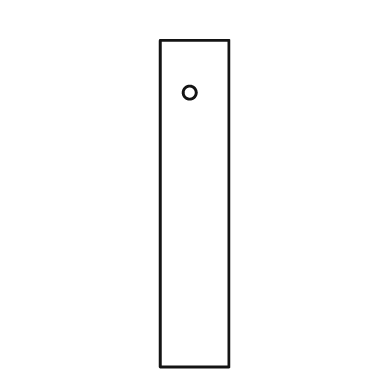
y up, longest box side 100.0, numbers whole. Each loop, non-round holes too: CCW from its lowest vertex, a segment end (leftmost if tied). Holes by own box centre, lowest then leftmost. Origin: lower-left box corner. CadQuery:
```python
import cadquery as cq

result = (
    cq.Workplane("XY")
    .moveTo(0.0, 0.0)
    .lineTo(21.0, 0.0)
    .lineTo(21.0, 100.0)
    .lineTo(0.0, 100.0)
    .close()
    .moveTo(9.0, 84.0)
    .circle(2.0)
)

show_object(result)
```